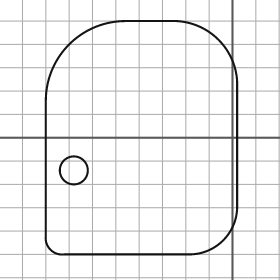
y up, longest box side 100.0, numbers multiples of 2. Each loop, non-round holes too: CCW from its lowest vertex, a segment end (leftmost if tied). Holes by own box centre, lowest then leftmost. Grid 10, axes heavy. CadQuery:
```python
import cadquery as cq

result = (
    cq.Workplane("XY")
    .moveTo(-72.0, -50.0)
    .lineTo(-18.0, -50.0)
    .threePointArc((-4.0, -44.0), (2.0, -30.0))
    .lineTo(2.0, 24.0)
    .threePointArc((-6.0, 42.0), (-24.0, 50.0))
    .lineTo(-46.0, 50.0)
    .threePointArc((-70.0, 40.0), (-80.0, 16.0))
    .lineTo(-80.0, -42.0)
    .threePointArc((-78.0, -48.0), (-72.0, -50.0))
    .close()
    .moveTo(-68.0, -14.0)
    .circle(6.0)
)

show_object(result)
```